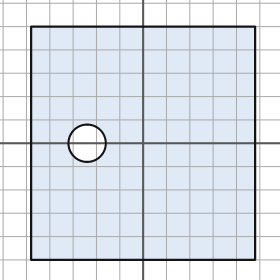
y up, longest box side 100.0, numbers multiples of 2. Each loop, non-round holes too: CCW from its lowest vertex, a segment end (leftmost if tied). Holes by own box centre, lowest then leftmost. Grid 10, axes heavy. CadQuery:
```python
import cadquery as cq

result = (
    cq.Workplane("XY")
    .moveTo(-48.0, -50.0)
    .lineTo(48.0, -50.0)
    .lineTo(48.0, 50.0)
    .lineTo(-48.0, 50.0)
    .close()
    .moveTo(-24.0, 0.0)
    .circle(8.0)
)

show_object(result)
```